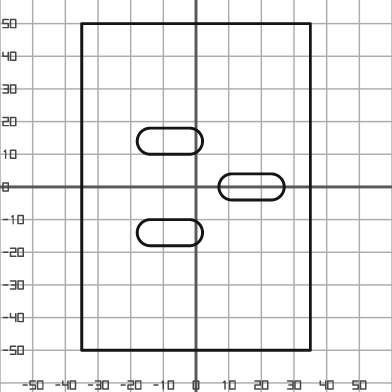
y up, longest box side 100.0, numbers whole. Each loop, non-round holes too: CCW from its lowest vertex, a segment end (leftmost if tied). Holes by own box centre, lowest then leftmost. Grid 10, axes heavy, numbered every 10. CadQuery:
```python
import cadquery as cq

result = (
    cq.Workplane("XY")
    .moveTo(-35.0, -50.0)
    .lineTo(35.0, -50.0)
    .lineTo(35.0, 50.0)
    .lineTo(-35.0, 50.0)
    .close()
    .moveTo(-14.0, -18.0)
    .lineTo(-2.0, -18.0)
    .threePointArc((2.0, -14.0), (-2.0, -10.0))
    .lineTo(-14.0, -10.0)
    .threePointArc((-18.0, -14.0), (-14.0, -18.0))
    .close()
    .moveTo(11.0, -4.0)
    .lineTo(23.0, -4.0)
    .threePointArc((27.0, 0.0), (23.0, 4.0))
    .lineTo(11.0, 4.0)
    .threePointArc((7.0, 0.0), (11.0, -4.0))
    .close()
    .moveTo(-14.0, 10.0)
    .lineTo(-2.0, 10.0)
    .threePointArc((2.0, 14.0), (-2.0, 18.0))
    .lineTo(-14.0, 18.0)
    .threePointArc((-18.0, 14.0), (-14.0, 10.0))
    .close()
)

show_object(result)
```